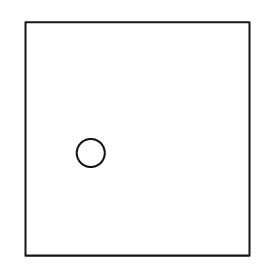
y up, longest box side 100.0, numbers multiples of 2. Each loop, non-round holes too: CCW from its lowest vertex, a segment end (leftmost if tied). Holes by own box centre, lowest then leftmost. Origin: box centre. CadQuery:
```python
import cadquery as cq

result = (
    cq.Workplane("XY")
    .moveTo(-48.0, -50.0)
    .lineTo(48.0, -50.0)
    .lineTo(48.0, 50.0)
    .lineTo(-48.0, 50.0)
    .close()
    .moveTo(-20.0, -6.0)
    .circle(6.0)
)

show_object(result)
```